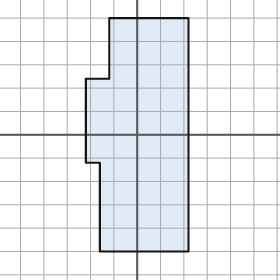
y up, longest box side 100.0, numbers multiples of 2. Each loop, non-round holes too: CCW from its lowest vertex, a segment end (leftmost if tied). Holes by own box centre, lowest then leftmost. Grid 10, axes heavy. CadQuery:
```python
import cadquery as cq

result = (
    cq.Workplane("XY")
    .moveTo(-16.0, -50.0)
    .lineTo(22.0, -50.0)
    .lineTo(22.0, 50.0)
    .lineTo(-12.0, 50.0)
    .lineTo(-12.0, 24.0)
    .lineTo(-22.0, 24.0)
    .lineTo(-22.0, -12.0)
    .lineTo(-16.0, -12.0)
    .close()
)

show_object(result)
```